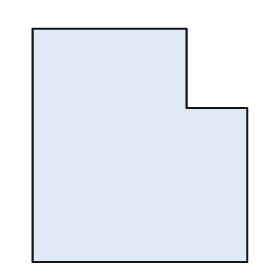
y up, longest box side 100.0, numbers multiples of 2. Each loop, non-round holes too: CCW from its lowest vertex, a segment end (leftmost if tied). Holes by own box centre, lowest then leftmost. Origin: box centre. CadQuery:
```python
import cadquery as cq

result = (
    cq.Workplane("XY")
    .moveTo(-46.0, -50.0)
    .lineTo(46.0, -50.0)
    .lineTo(46.0, 16.0)
    .lineTo(20.0, 16.0)
    .lineTo(20.0, 50.0)
    .lineTo(-46.0, 50.0)
    .close()
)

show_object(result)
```